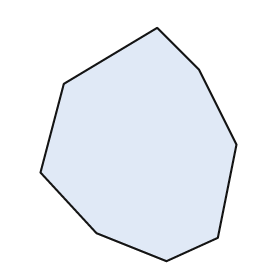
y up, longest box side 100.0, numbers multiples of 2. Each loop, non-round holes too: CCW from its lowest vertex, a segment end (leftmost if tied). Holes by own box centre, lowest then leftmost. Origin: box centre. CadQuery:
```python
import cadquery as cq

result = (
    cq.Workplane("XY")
    .moveTo(12.0, -50.0)
    .lineTo(34.0, -40.0)
    .lineTo(42.0, 0.0)
    .lineTo(26.0, 32.0)
    .lineTo(8.0, 50.0)
    .lineTo(-32.0, 26.0)
    .lineTo(-42.0, -12.0)
    .lineTo(-18.0, -38.0)
    .close()
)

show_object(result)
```